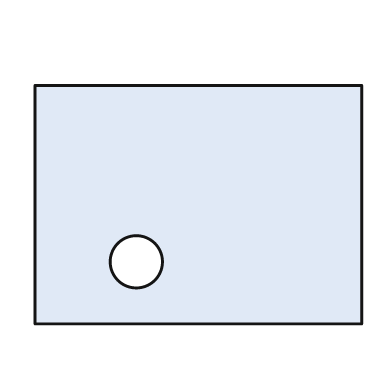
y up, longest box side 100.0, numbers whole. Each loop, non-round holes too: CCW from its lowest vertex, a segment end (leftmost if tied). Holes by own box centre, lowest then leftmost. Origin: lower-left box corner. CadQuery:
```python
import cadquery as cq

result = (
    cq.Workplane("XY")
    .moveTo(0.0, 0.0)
    .lineTo(100.0, 0.0)
    .lineTo(100.0, 73.0)
    .lineTo(0.0, 73.0)
    .close()
    .moveTo(31.0, 19.0)
    .circle(8.0)
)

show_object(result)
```